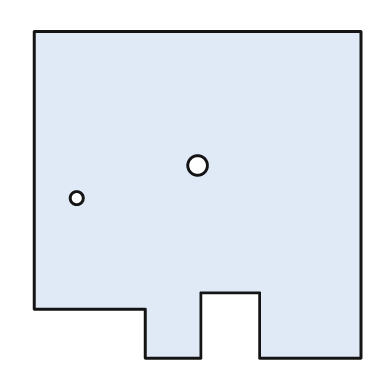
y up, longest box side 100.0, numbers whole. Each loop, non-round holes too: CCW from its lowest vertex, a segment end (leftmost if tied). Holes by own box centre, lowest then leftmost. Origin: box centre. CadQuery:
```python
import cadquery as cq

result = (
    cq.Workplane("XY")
    .moveTo(-16.0, -50.0)
    .lineTo(1.0, -50.0)
    .lineTo(1.0, -30.0)
    .lineTo(19.0, -30.0)
    .lineTo(19.0, -50.0)
    .lineTo(50.0, -50.0)
    .lineTo(50.0, 50.0)
    .lineTo(-50.0, 50.0)
    .lineTo(-50.0, -35.0)
    .lineTo(-16.0, -35.0)
    .close()
    .moveTo(-37.0, -1.0)
    .circle(2.0)
    .moveTo(0.0, 9.0)
    .circle(3.0)
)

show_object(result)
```